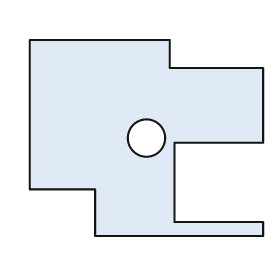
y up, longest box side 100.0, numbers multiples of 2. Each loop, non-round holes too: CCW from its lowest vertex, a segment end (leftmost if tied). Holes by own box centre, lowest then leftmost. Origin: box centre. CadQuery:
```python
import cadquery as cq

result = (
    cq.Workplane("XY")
    .moveTo(-22.0, -42.0)
    .lineTo(50.0, -42.0)
    .lineTo(50.0, -36.0)
    .lineTo(12.0, -36.0)
    .lineTo(12.0, -2.0)
    .lineTo(50.0, -2.0)
    .lineTo(50.0, 30.0)
    .lineTo(10.0, 30.0)
    .lineTo(10.0, 42.0)
    .lineTo(-50.0, 42.0)
    .lineTo(-50.0, -22.0)
    .lineTo(-22.0, -22.0)
    .close()
    .moveTo(0.0, 0.0)
    .circle(8.0)
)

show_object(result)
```